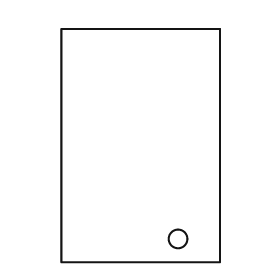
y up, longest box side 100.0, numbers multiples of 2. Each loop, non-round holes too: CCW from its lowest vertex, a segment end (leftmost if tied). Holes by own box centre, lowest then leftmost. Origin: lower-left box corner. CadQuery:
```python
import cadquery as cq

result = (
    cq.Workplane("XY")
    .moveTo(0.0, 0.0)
    .lineTo(68.0, 0.0)
    .lineTo(68.0, 100.0)
    .lineTo(0.0, 100.0)
    .close()
    .moveTo(50.0, 10.0)
    .circle(4.0)
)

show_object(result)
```